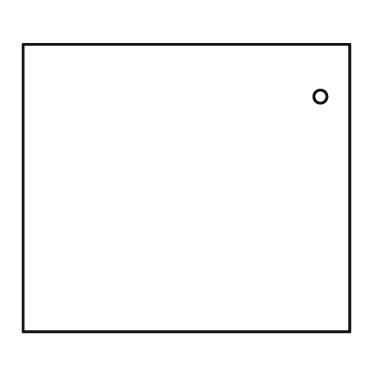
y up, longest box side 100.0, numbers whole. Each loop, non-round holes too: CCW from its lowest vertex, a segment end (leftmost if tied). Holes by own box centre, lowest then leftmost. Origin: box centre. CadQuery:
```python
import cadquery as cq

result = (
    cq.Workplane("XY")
    .moveTo(-50.0, -44.0)
    .lineTo(50.0, -44.0)
    .lineTo(50.0, 44.0)
    .lineTo(-50.0, 44.0)
    .close()
    .moveTo(41.0, 28.0)
    .circle(2.0)
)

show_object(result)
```